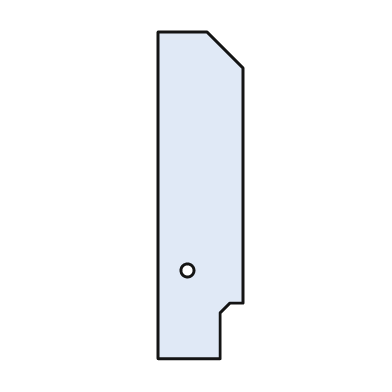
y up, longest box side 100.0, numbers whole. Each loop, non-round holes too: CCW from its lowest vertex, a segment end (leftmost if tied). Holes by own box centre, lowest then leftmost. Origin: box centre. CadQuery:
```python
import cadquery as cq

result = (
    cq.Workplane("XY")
    .moveTo(-13.0, -50.0)
    .lineTo(6.0, -50.0)
    .lineTo(6.0, -36.0)
    .lineTo(9.0, -33.0)
    .lineTo(13.0, -33.0)
    .lineTo(13.0, 39.0)
    .lineTo(2.0, 50.0)
    .lineTo(-13.0, 50.0)
    .close()
    .moveTo(-4.0, -23.0)
    .circle(2.0)
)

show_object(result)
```